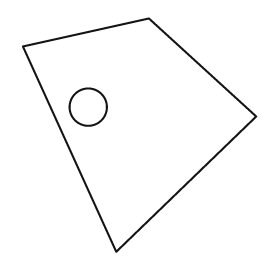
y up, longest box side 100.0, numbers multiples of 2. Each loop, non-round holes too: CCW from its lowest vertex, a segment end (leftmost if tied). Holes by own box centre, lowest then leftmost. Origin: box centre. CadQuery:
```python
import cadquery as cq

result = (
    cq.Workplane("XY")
    .moveTo(-10.0, -50.0)
    .lineTo(50.0, 8.0)
    .lineTo(4.0, 50.0)
    .lineTo(-50.0, 38.0)
    .close()
    .moveTo(-22.0, 12.0)
    .circle(8.0)
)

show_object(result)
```